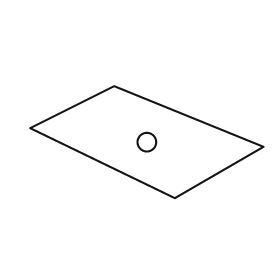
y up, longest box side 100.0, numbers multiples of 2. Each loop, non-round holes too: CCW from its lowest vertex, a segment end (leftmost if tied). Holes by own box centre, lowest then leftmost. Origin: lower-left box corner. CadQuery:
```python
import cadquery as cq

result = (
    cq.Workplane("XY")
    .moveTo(62.0, 0.0)
    .lineTo(100.0, 22.0)
    .lineTo(36.0, 48.0)
    .lineTo(0.0, 30.0)
    .close()
    .moveTo(50.0, 24.0)
    .circle(4.0)
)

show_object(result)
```